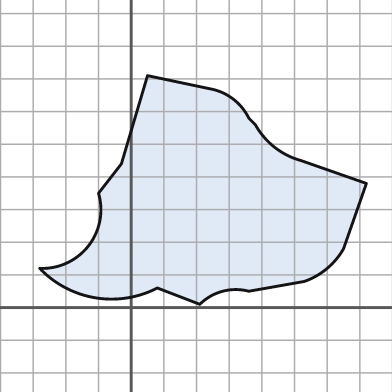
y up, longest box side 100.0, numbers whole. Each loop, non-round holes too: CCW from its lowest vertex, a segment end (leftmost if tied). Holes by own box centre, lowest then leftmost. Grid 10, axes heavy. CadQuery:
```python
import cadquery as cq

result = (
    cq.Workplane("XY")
    .moveTo(21.0, 1.0)
    .threePointArc((28.0, 5.0), (36.0, 5.0))
    .lineTo(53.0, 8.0)
    .threePointArc((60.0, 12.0), (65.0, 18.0))
    .lineTo(72.0, 38.0)
    .lineTo(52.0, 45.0)
    .threePointArc((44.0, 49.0), (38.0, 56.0))
    .lineTo(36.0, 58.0)
    .threePointArc((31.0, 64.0), (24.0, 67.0))
    .lineTo(5.0, 71.0)
    .lineTo(-3.0, 44.0)
    .lineTo(-10.0, 35.0)
    .threePointArc((-13.0, 19.0), (-28.0, 12.0))
    .threePointArc((-11.0, 3.0), (8.0, 6.0))
    .close()
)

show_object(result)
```